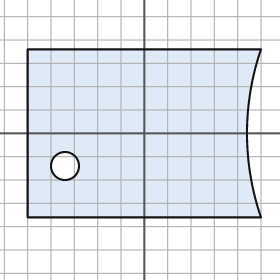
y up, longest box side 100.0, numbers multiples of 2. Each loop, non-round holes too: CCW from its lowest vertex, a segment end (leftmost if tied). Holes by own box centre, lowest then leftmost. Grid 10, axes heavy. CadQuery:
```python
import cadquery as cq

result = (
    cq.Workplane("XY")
    .moveTo(-50.0, -36.0)
    .lineTo(50.0, -36.0)
    .threePointArc((44.0, 0.0), (50.0, 36.0))
    .lineTo(-50.0, 36.0)
    .close()
    .moveTo(-34.0, -14.0)
    .circle(6.0)
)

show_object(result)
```